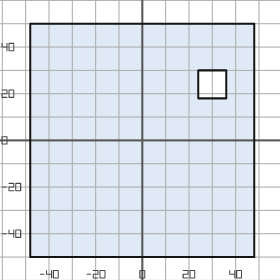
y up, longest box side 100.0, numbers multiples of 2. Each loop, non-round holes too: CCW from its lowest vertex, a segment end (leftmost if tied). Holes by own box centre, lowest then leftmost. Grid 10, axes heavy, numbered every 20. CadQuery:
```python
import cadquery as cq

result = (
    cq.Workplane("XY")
    .moveTo(-48.0, -50.0)
    .lineTo(48.0, -50.0)
    .lineTo(48.0, 50.0)
    .lineTo(-48.0, 50.0)
    .close()
    .moveTo(24.0, 18.0)
    .lineTo(36.0, 18.0)
    .lineTo(36.0, 30.0)
    .lineTo(24.0, 30.0)
    .close()
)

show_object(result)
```